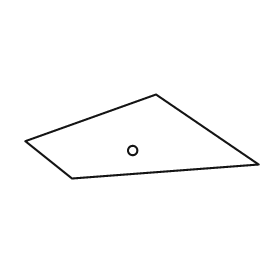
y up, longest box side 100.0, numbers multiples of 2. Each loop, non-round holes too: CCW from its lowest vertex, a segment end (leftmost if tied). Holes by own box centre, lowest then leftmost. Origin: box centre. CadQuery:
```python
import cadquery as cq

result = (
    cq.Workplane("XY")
    .moveTo(-30.0, -18.0)
    .lineTo(50.0, -12.0)
    .lineTo(6.0, 18.0)
    .lineTo(-50.0, -2.0)
    .close()
    .moveTo(-4.0, -6.0)
    .circle(2.0)
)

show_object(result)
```